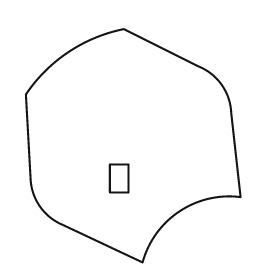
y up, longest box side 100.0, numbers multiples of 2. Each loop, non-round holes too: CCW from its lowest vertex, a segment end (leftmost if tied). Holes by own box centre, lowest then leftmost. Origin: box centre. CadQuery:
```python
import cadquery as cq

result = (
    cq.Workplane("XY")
    .moveTo(4.0, -50.0)
    .threePointArc((20.0, -28.0), (46.0, -22.0))
    .lineTo(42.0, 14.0)
    .threePointArc((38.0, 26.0), (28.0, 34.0))
    .lineTo(-4.0, 50.0)
    .threePointArc((-28.0, 40.0), (-46.0, 22.0))
    .lineTo(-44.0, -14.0)
    .threePointArc((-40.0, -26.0), (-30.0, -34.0))
    .close()
    .moveTo(-10.0, -20.0)
    .lineTo(-2.0, -20.0)
    .lineTo(-2.0, -8.0)
    .lineTo(-10.0, -8.0)
    .close()
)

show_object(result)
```